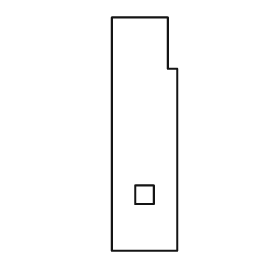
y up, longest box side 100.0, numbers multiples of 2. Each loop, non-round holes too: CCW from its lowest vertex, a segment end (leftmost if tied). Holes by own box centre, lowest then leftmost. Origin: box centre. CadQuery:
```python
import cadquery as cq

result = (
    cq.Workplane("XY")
    .moveTo(-14.0, -50.0)
    .lineTo(14.0, -50.0)
    .lineTo(14.0, 28.0)
    .lineTo(10.0, 28.0)
    .lineTo(10.0, 50.0)
    .lineTo(-14.0, 50.0)
    .close()
    .moveTo(-4.0, -30.0)
    .lineTo(4.0, -30.0)
    .lineTo(4.0, -22.0)
    .lineTo(-4.0, -22.0)
    .close()
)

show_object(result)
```